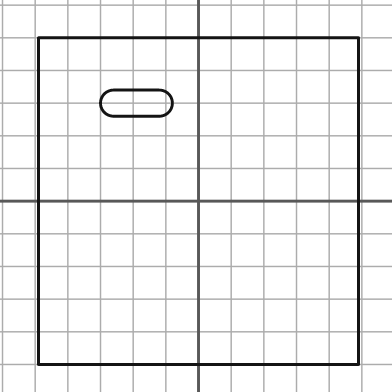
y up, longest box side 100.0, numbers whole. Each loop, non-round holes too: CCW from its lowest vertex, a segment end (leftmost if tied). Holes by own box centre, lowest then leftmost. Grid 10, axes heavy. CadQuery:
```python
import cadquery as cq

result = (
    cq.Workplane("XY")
    .moveTo(-49.0, -50.0)
    .lineTo(49.0, -50.0)
    .lineTo(49.0, 50.0)
    .lineTo(-49.0, 50.0)
    .close()
    .moveTo(-26.0, 26.0)
    .lineTo(-12.0, 26.0)
    .threePointArc((-8.0, 30.0), (-12.0, 34.0))
    .lineTo(-26.0, 34.0)
    .threePointArc((-30.0, 30.0), (-26.0, 26.0))
    .close()
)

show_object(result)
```